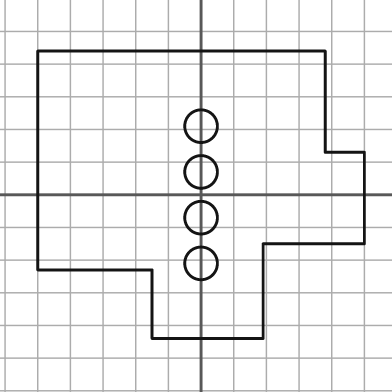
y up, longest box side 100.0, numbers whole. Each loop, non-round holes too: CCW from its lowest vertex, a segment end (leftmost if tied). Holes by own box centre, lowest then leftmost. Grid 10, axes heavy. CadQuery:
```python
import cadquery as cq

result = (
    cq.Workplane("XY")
    .moveTo(-15.0, -44.0)
    .lineTo(19.0, -44.0)
    .lineTo(19.0, -15.0)
    .lineTo(50.0, -15.0)
    .lineTo(50.0, 13.0)
    .lineTo(38.0, 13.0)
    .lineTo(38.0, 44.0)
    .lineTo(-50.0, 44.0)
    .lineTo(-50.0, -23.0)
    .lineTo(-15.0, -23.0)
    .close()
    .moveTo(0.0, -21.0)
    .circle(5.0)
    .moveTo(0.0, -7.0)
    .circle(5.0)
    .moveTo(0.0, 7.0)
    .circle(5.0)
    .moveTo(0.0, 21.0)
    .circle(5.0)
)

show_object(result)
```